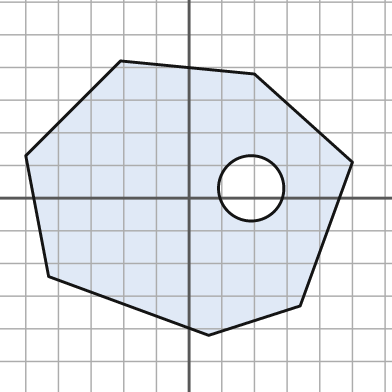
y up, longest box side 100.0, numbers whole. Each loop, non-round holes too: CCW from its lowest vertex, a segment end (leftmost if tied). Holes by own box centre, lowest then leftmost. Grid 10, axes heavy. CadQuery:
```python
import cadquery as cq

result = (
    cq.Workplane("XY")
    .moveTo(6.0, -42.0)
    .lineTo(34.0, -33.0)
    .lineTo(50.0, 11.0)
    .lineTo(20.0, 38.0)
    .lineTo(-21.0, 42.0)
    .lineTo(-50.0, 13.0)
    .lineTo(-43.0, -24.0)
    .close()
    .moveTo(19.0, 3.0)
    .circle(10.0)
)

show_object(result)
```